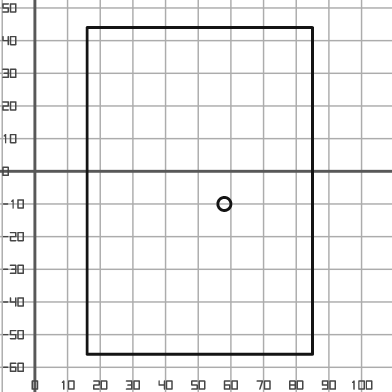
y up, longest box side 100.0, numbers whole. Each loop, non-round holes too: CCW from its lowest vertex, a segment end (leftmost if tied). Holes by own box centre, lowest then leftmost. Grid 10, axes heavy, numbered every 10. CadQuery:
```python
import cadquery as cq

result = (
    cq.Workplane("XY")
    .moveTo(16.0, -56.0)
    .lineTo(85.0, -56.0)
    .lineTo(85.0, 44.0)
    .lineTo(16.0, 44.0)
    .close()
    .moveTo(58.0, -10.0)
    .circle(2.0)
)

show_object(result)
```